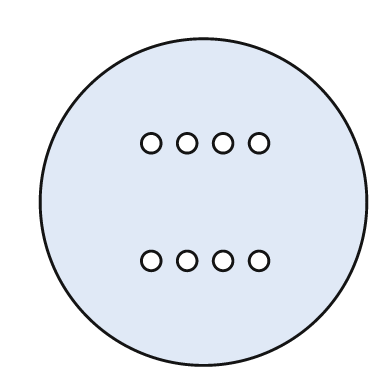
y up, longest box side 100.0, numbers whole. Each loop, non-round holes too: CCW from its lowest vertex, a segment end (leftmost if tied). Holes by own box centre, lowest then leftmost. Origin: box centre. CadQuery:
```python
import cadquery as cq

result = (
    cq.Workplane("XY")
    .moveTo(0.0, 0.0)
    .circle(50.0)
    .moveTo(-16.0, -18.0)
    .circle(3.0)
    .moveTo(-5.0, -18.0)
    .circle(3.0)
    .moveTo(6.0, -18.0)
    .circle(3.0)
    .moveTo(17.0, -18.0)
    .circle(3.0)
    .moveTo(-16.0, 18.0)
    .circle(3.0)
    .moveTo(-5.0, 18.0)
    .circle(3.0)
    .moveTo(6.0, 18.0)
    .circle(3.0)
    .moveTo(17.0, 18.0)
    .circle(3.0)
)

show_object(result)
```